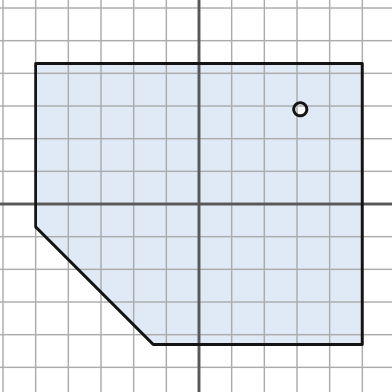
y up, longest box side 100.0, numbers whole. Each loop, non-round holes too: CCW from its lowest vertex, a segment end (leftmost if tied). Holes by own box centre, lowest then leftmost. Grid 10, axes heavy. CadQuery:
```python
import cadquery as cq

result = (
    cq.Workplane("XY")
    .moveTo(-14.0, -43.0)
    .lineTo(50.0, -43.0)
    .lineTo(50.0, 43.0)
    .lineTo(-50.0, 43.0)
    .lineTo(-50.0, -7.0)
    .close()
    .moveTo(31.0, 29.0)
    .circle(2.0)
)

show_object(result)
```